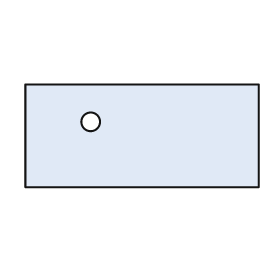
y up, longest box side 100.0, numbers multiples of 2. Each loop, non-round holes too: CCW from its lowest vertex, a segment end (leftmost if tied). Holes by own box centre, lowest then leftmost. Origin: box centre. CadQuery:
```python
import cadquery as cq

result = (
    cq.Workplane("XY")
    .moveTo(-50.0, -22.0)
    .lineTo(50.0, -22.0)
    .lineTo(50.0, 22.0)
    .lineTo(-50.0, 22.0)
    .close()
    .moveTo(-22.0, 6.0)
    .circle(4.0)
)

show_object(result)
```